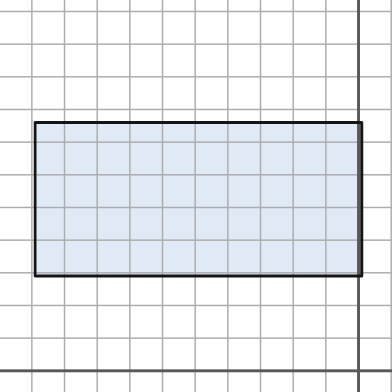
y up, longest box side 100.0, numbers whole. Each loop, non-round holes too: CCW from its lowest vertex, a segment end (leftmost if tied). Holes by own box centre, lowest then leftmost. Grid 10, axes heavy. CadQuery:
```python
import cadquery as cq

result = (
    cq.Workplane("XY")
    .moveTo(-99.0, 29.0)
    .lineTo(1.0, 29.0)
    .lineTo(1.0, 76.0)
    .lineTo(-99.0, 76.0)
    .close()
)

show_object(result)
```